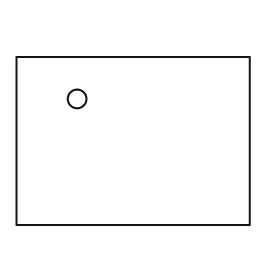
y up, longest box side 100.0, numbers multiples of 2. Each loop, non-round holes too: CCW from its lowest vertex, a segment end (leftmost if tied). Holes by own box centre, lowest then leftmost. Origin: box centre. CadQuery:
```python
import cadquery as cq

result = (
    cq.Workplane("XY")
    .moveTo(-50.0, -36.0)
    .lineTo(50.0, -36.0)
    .lineTo(50.0, 36.0)
    .lineTo(-50.0, 36.0)
    .close()
    .moveTo(-24.0, 18.0)
    .circle(4.0)
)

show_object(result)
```